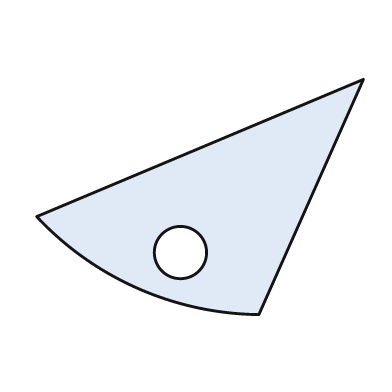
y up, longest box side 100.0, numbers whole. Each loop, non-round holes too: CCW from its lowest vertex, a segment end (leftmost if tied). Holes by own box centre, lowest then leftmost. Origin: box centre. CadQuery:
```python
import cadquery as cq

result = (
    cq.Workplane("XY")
    .moveTo(18.0, -36.0)
    .lineTo(50.0, 36.0)
    .lineTo(-50.0, -6.0)
    .threePointArc((-19.0, -28.0), (18.0, -36.0))
    .close()
    .moveTo(-6.0, -17.0)
    .circle(8.0)
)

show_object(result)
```